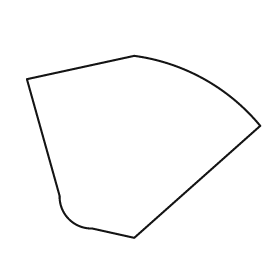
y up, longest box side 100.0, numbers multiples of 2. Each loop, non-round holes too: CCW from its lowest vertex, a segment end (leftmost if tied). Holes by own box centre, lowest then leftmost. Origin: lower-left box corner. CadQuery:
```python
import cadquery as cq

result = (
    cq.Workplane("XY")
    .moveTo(46.0, 0.0)
    .lineTo(100.0, 48.0)
    .threePointArc((76.0, 68.0), (46.0, 78.0))
    .lineTo(0.0, 68.0)
    .lineTo(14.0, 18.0)
    .threePointArc((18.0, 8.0), (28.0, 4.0))
    .close()
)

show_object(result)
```